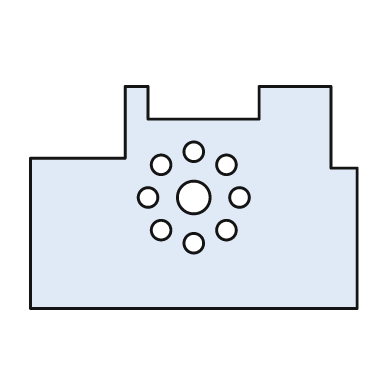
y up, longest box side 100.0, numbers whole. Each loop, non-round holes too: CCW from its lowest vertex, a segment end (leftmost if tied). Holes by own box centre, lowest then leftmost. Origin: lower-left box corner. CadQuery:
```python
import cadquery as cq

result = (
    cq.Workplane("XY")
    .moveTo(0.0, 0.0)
    .lineTo(100.0, 0.0)
    .lineTo(100.0, 43.0)
    .lineTo(92.0, 43.0)
    .lineTo(92.0, 68.0)
    .lineTo(70.0, 68.0)
    .lineTo(70.0, 58.0)
    .lineTo(36.0, 58.0)
    .lineTo(36.0, 68.0)
    .lineTo(29.0, 68.0)
    .lineTo(29.0, 46.0)
    .lineTo(0.0, 46.0)
    .close()
    .moveTo(50.0, 20.0)
    .circle(3.0)
    .moveTo(40.0, 24.0)
    .circle(3.0)
    .moveTo(60.0, 24.0)
    .circle(3.0)
    .moveTo(36.0, 34.0)
    .circle(3.0)
    .moveTo(50.0, 34.0)
    .circle(5.0)
    .moveTo(64.0, 34.0)
    .circle(3.0)
    .moveTo(40.0, 44.0)
    .circle(3.0)
    .moveTo(60.0, 44.0)
    .circle(3.0)
    .moveTo(50.0, 48.0)
    .circle(3.0)
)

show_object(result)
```